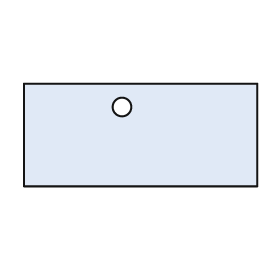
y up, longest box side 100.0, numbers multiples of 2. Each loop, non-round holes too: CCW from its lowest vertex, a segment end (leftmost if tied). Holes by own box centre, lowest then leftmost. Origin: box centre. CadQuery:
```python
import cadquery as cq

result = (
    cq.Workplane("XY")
    .moveTo(-50.0, -22.0)
    .lineTo(50.0, -22.0)
    .lineTo(50.0, 22.0)
    .lineTo(-50.0, 22.0)
    .close()
    .moveTo(-8.0, 12.0)
    .circle(4.0)
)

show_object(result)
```